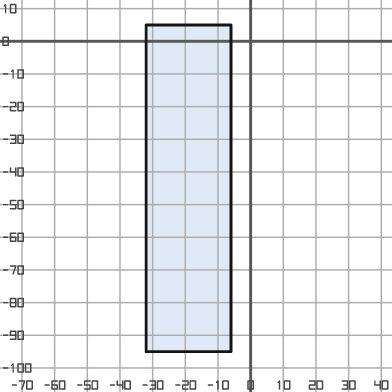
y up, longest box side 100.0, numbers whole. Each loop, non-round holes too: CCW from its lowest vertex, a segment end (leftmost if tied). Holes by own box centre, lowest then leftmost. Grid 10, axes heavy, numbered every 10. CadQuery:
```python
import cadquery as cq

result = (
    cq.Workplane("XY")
    .moveTo(-32.0, -95.0)
    .lineTo(-6.0, -95.0)
    .lineTo(-6.0, 5.0)
    .lineTo(-32.0, 5.0)
    .close()
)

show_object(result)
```